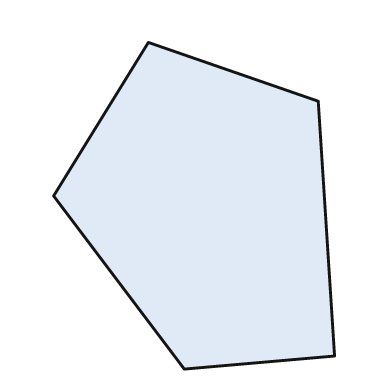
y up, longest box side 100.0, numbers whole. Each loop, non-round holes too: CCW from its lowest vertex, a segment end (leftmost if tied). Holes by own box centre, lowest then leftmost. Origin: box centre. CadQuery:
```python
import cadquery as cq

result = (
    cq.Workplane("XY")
    .moveTo(-3.0, -50.0)
    .lineTo(43.0, -46.0)
    .lineTo(38.0, 32.0)
    .lineTo(-14.0, 50.0)
    .lineTo(-43.0, 3.0)
    .close()
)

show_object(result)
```